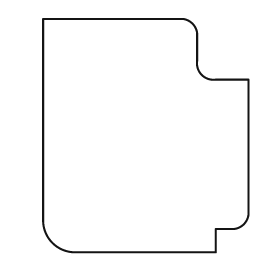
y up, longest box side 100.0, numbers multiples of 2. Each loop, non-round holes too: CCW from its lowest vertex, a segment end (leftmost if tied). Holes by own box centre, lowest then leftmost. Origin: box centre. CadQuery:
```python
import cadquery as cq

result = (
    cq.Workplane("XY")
    .moveTo(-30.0, -50.0)
    .lineTo(30.0, -50.0)
    .lineTo(30.0, -40.0)
    .lineTo(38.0, -40.0)
    .threePointArc((42.0, -38.0), (44.0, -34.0))
    .lineTo(44.0, 24.0)
    .lineTo(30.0, 24.0)
    .threePointArc((24.0, 26.0), (22.0, 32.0))
    .lineTo(22.0, 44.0)
    .threePointArc((20.0, 48.0), (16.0, 50.0))
    .lineTo(-44.0, 50.0)
    .lineTo(-44.0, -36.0)
    .threePointArc((-40.0, -46.0), (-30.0, -50.0))
    .close()
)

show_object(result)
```